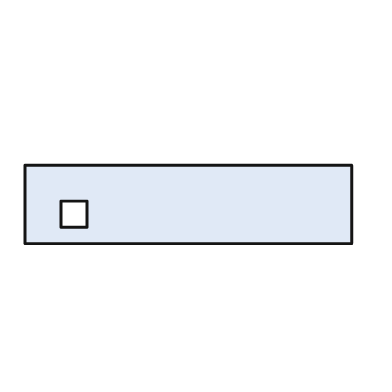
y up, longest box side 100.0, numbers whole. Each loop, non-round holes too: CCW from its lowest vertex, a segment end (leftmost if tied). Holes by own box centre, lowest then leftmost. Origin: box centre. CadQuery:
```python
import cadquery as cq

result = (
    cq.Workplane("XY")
    .moveTo(-50.0, -12.0)
    .lineTo(50.0, -12.0)
    .lineTo(50.0, 12.0)
    .lineTo(-50.0, 12.0)
    .close()
    .moveTo(-39.0, -7.0)
    .lineTo(-31.0, -7.0)
    .lineTo(-31.0, 1.0)
    .lineTo(-39.0, 1.0)
    .close()
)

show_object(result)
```